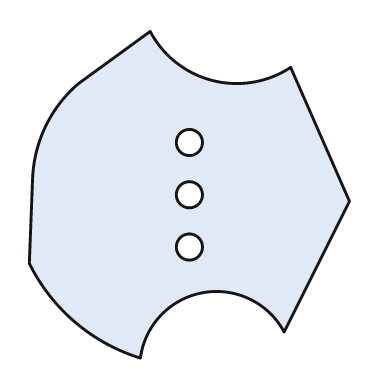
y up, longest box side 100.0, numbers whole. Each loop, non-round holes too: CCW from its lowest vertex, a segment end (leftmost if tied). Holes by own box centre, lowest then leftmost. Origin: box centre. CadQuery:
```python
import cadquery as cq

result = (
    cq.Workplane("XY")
    .moveTo(-15.0, -50.0)
    .threePointArc((4.0, -30.0), (29.0, -42.0))
    .lineTo(49.0, -2.0)
    .lineTo(31.0, 39.0)
    .threePointArc((7.0, 35.0), (-12.0, 50.0))
    .lineTo(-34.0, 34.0)
    .threePointArc((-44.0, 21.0), (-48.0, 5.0))
    .lineTo(-49.0, -21.0)
    .threePointArc((-35.0, -39.0), (-15.0, -50.0))
    .close()
    .moveTo(0.0, -16.0)
    .circle(4.0)
    .moveTo(0.0, 0.0)
    .circle(4.0)
    .moveTo(0.0, 16.0)
    .circle(4.0)
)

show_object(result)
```